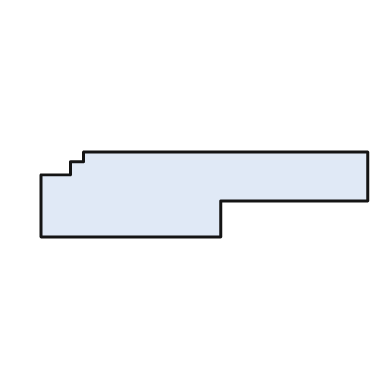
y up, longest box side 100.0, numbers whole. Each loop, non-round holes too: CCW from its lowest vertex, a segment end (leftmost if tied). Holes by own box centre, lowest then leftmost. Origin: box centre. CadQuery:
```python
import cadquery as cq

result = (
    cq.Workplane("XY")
    .moveTo(-50.0, -13.0)
    .lineTo(5.0, -13.0)
    .lineTo(5.0, -2.0)
    .lineTo(50.0, -2.0)
    .lineTo(50.0, 13.0)
    .lineTo(-37.0, 13.0)
    .lineTo(-37.0, 10.0)
    .lineTo(-41.0, 10.0)
    .lineTo(-41.0, 6.0)
    .lineTo(-50.0, 6.0)
    .close()
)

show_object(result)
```